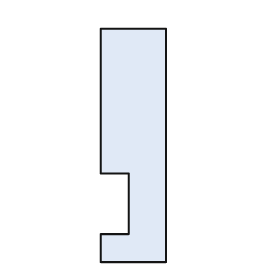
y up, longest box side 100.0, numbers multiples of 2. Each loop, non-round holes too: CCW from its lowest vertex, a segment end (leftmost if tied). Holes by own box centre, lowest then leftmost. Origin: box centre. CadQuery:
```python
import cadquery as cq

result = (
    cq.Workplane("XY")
    .moveTo(-14.0, -50.0)
    .lineTo(14.0, -50.0)
    .lineTo(14.0, 50.0)
    .lineTo(-14.0, 50.0)
    .lineTo(-14.0, -12.0)
    .lineTo(-2.0, -12.0)
    .lineTo(-2.0, -38.0)
    .lineTo(-14.0, -38.0)
    .close()
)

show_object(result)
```